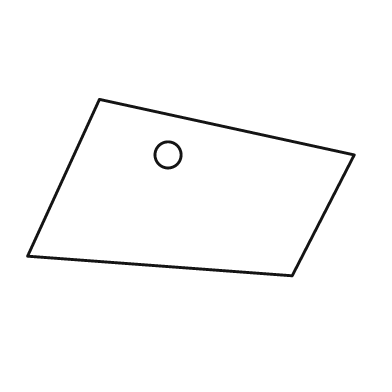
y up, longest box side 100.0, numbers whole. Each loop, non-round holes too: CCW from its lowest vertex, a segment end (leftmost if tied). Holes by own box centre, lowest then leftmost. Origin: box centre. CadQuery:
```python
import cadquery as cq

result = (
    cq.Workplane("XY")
    .moveTo(31.0, -27.0)
    .lineTo(50.0, 10.0)
    .lineTo(-28.0, 27.0)
    .lineTo(-50.0, -21.0)
    .close()
    .moveTo(-7.0, 10.0)
    .circle(4.0)
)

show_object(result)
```